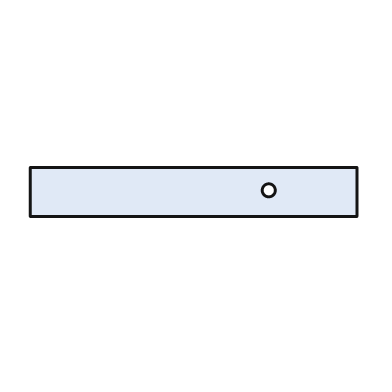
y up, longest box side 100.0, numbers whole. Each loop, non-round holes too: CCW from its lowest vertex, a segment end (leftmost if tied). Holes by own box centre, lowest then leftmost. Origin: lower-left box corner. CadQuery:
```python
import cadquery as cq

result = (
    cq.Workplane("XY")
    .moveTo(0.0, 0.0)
    .lineTo(100.0, 0.0)
    .lineTo(100.0, 15.0)
    .lineTo(0.0, 15.0)
    .close()
    .moveTo(73.0, 8.0)
    .circle(2.0)
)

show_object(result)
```